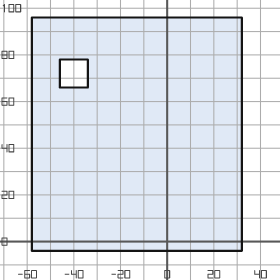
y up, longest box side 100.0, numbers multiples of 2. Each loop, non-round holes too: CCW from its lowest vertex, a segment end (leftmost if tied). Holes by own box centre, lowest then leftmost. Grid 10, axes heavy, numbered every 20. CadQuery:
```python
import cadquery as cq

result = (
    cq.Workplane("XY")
    .moveTo(-58.0, -4.0)
    .lineTo(32.0, -4.0)
    .lineTo(32.0, 96.0)
    .lineTo(-58.0, 96.0)
    .close()
    .moveTo(-46.0, 66.0)
    .lineTo(-34.0, 66.0)
    .lineTo(-34.0, 78.0)
    .lineTo(-46.0, 78.0)
    .close()
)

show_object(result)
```